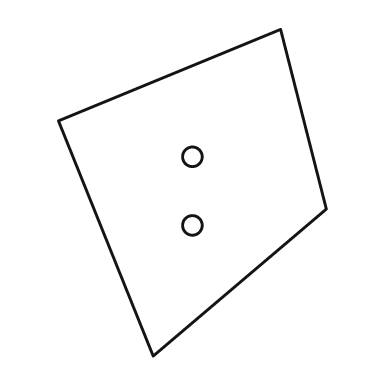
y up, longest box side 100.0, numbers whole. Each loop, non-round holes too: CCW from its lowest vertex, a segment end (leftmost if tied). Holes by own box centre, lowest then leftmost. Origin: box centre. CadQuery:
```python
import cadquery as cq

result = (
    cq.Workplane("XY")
    .moveTo(-12.0, -50.0)
    .lineTo(41.0, -5.0)
    .lineTo(27.0, 50.0)
    .lineTo(-41.0, 22.0)
    .close()
    .moveTo(0.0, -10.0)
    .circle(3.0)
    .moveTo(0.0, 11.0)
    .circle(3.0)
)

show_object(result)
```